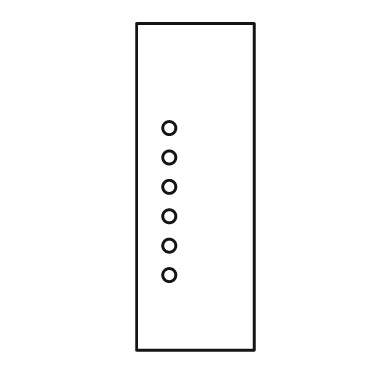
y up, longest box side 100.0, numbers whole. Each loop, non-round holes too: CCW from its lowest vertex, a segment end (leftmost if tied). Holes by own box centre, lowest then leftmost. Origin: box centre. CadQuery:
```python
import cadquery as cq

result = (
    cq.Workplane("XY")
    .moveTo(-18.0, -50.0)
    .lineTo(18.0, -50.0)
    .lineTo(18.0, 50.0)
    .lineTo(-18.0, 50.0)
    .close()
    .moveTo(-8.0, -27.0)
    .circle(2.0)
    .moveTo(-8.0, -18.0)
    .circle(2.0)
    .moveTo(-8.0, -9.0)
    .circle(2.0)
    .moveTo(-8.0, 0.0)
    .circle(2.0)
    .moveTo(-8.0, 9.0)
    .circle(2.0)
    .moveTo(-8.0, 18.0)
    .circle(2.0)
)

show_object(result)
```